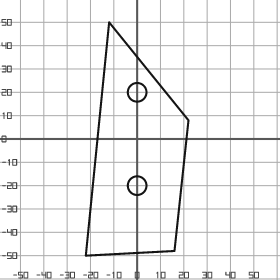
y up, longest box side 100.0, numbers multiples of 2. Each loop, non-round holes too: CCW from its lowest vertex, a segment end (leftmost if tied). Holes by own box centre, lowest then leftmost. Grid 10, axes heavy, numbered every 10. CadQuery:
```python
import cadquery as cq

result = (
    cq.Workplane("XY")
    .moveTo(-22.0, -50.0)
    .lineTo(16.0, -48.0)
    .lineTo(22.0, 8.0)
    .lineTo(-12.0, 50.0)
    .close()
    .moveTo(0.0, -20.0)
    .circle(4.0)
    .moveTo(0.0, 20.0)
    .circle(4.0)
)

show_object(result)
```